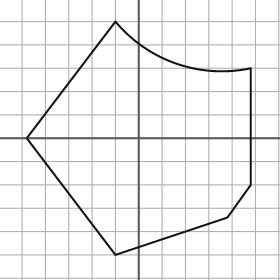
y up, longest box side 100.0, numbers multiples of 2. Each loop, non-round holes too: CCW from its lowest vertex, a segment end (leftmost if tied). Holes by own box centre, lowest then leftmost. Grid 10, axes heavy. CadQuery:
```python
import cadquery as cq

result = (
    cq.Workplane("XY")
    .moveTo(-10.0, -50.0)
    .lineTo(38.0, -34.0)
    .lineTo(48.0, -20.0)
    .lineTo(48.0, 30.0)
    .threePointArc((16.0, 32.0), (-10.0, 50.0))
    .lineTo(-48.0, 0.0)
    .close()
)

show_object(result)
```